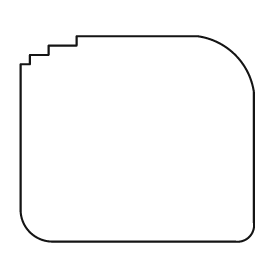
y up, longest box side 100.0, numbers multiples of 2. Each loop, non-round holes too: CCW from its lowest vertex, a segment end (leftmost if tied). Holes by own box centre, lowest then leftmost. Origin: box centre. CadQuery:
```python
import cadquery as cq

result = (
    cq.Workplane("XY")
    .moveTo(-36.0, -44.0)
    .lineTo(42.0, -44.0)
    .threePointArc((48.0, -42.0), (50.0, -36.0))
    .lineTo(50.0, 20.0)
    .threePointArc((42.0, 36.0), (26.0, 44.0))
    .lineTo(-26.0, 44.0)
    .lineTo(-26.0, 40.0)
    .lineTo(-38.0, 40.0)
    .lineTo(-38.0, 36.0)
    .lineTo(-46.0, 36.0)
    .lineTo(-46.0, 32.0)
    .lineTo(-50.0, 32.0)
    .lineTo(-50.0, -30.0)
    .threePointArc((-46.0, -40.0), (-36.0, -44.0))
    .close()
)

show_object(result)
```